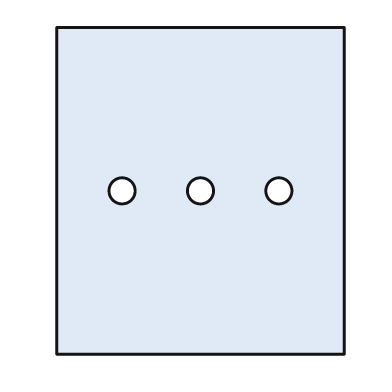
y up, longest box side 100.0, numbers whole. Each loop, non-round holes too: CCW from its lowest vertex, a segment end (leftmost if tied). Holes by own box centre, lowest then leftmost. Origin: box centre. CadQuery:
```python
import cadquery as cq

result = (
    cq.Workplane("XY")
    .moveTo(-44.0, -50.0)
    .lineTo(44.0, -50.0)
    .lineTo(44.0, 50.0)
    .lineTo(-44.0, 50.0)
    .close()
    .moveTo(-24.0, 0.0)
    .circle(4.0)
    .moveTo(0.0, 0.0)
    .circle(4.0)
    .moveTo(24.0, 0.0)
    .circle(4.0)
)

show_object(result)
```